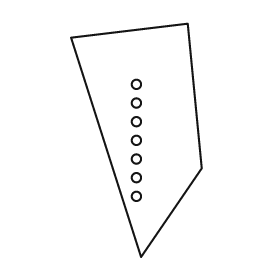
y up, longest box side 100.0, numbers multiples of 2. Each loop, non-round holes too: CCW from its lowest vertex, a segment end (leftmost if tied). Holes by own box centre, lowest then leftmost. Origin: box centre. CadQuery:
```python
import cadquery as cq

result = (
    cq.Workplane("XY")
    .moveTo(2.0, -50.0)
    .lineTo(28.0, -12.0)
    .lineTo(22.0, 50.0)
    .lineTo(-28.0, 44.0)
    .close()
    .moveTo(0.0, -24.0)
    .circle(2.0)
    .moveTo(0.0, -16.0)
    .circle(2.0)
    .moveTo(0.0, -8.0)
    .circle(2.0)
    .moveTo(0.0, 0.0)
    .circle(2.0)
    .moveTo(0.0, 8.0)
    .circle(2.0)
    .moveTo(0.0, 16.0)
    .circle(2.0)
    .moveTo(0.0, 24.0)
    .circle(2.0)
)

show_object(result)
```